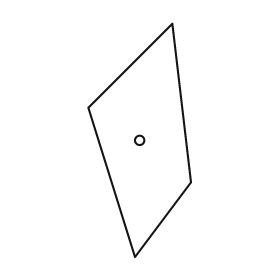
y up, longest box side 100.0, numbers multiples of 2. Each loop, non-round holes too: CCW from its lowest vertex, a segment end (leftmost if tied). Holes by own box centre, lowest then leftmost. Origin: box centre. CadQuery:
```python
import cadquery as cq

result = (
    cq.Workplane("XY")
    .moveTo(-2.0, -50.0)
    .lineTo(22.0, -18.0)
    .lineTo(14.0, 50.0)
    .lineTo(-22.0, 14.0)
    .close()
    .moveTo(0.0, 0.0)
    .circle(2.0)
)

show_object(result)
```